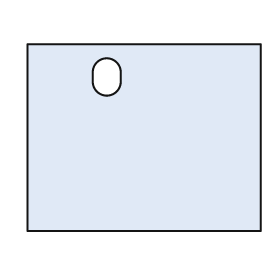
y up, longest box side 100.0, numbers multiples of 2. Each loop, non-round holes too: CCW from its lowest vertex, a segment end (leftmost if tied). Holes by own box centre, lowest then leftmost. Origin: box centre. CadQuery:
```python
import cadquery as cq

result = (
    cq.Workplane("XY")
    .moveTo(-50.0, -40.0)
    .lineTo(50.0, -40.0)
    .lineTo(50.0, 40.0)
    .lineTo(-50.0, 40.0)
    .close()
    .moveTo(-22.0, 24.0)
    .threePointArc((-16.0, 18.0), (-10.0, 24.0))
    .lineTo(-10.0, 28.0)
    .threePointArc((-16.0, 34.0), (-22.0, 28.0))
    .close()
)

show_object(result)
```